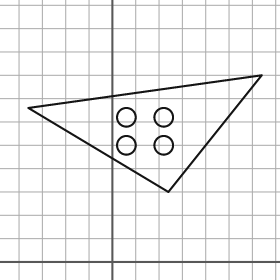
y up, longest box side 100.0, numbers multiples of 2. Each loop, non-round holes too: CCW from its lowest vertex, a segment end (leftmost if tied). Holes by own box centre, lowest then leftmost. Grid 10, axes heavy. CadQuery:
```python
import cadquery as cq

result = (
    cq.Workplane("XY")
    .moveTo(24.0, 30.0)
    .lineTo(64.0, 80.0)
    .lineTo(-36.0, 66.0)
    .close()
    .moveTo(6.0, 50.0)
    .circle(4.0)
    .moveTo(22.0, 50.0)
    .circle(4.0)
    .moveTo(6.0, 62.0)
    .circle(4.0)
    .moveTo(22.0, 62.0)
    .circle(4.0)
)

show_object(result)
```